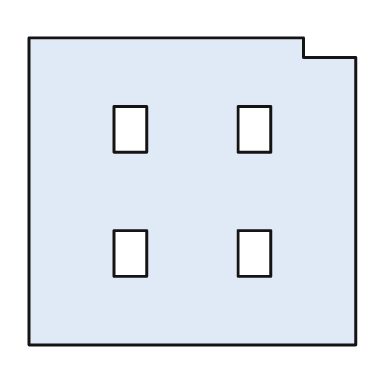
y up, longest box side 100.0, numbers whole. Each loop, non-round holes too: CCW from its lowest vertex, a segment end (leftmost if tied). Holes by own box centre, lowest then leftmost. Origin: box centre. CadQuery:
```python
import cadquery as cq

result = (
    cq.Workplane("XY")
    .moveTo(-50.0, -47.0)
    .lineTo(50.0, -47.0)
    .lineTo(50.0, 41.0)
    .lineTo(34.0, 41.0)
    .lineTo(34.0, 47.0)
    .lineTo(-50.0, 47.0)
    .close()
    .moveTo(-24.0, -26.0)
    .lineTo(-14.0, -26.0)
    .lineTo(-14.0, -12.0)
    .lineTo(-24.0, -12.0)
    .close()
    .moveTo(14.0, -26.0)
    .lineTo(24.0, -26.0)
    .lineTo(24.0, -12.0)
    .lineTo(14.0, -12.0)
    .close()
    .moveTo(-24.0, 12.0)
    .lineTo(-14.0, 12.0)
    .lineTo(-14.0, 26.0)
    .lineTo(-24.0, 26.0)
    .close()
    .moveTo(14.0, 12.0)
    .lineTo(24.0, 12.0)
    .lineTo(24.0, 26.0)
    .lineTo(14.0, 26.0)
    .close()
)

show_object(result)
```